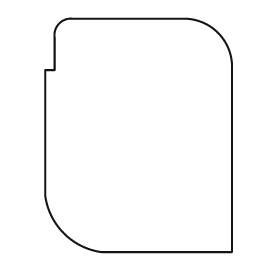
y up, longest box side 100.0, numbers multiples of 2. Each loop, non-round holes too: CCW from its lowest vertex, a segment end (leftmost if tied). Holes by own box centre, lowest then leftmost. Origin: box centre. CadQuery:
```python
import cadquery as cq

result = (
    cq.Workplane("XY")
    .moveTo(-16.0, -50.0)
    .lineTo(40.0, -50.0)
    .lineTo(40.0, 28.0)
    .threePointArc((34.0, 44.0), (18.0, 50.0))
    .lineTo(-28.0, 50.0)
    .threePointArc((-34.0, 48.0), (-36.0, 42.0))
    .lineTo(-36.0, 28.0)
    .lineTo(-40.0, 28.0)
    .lineTo(-40.0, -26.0)
    .threePointArc((-32.0, -42.0), (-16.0, -50.0))
    .close()
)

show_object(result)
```